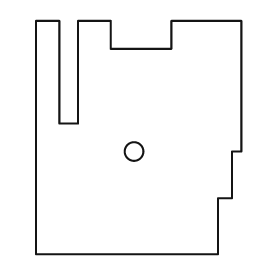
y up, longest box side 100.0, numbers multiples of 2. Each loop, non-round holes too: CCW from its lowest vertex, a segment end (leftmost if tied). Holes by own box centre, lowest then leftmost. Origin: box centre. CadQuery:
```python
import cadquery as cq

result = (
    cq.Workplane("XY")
    .moveTo(-44.0, -50.0)
    .lineTo(34.0, -50.0)
    .lineTo(34.0, -26.0)
    .lineTo(40.0, -26.0)
    .lineTo(40.0, -6.0)
    .lineTo(44.0, -6.0)
    .lineTo(44.0, 50.0)
    .lineTo(14.0, 50.0)
    .lineTo(14.0, 38.0)
    .lineTo(-12.0, 38.0)
    .lineTo(-12.0, 50.0)
    .lineTo(-26.0, 50.0)
    .lineTo(-26.0, 6.0)
    .lineTo(-34.0, 6.0)
    .lineTo(-34.0, 50.0)
    .lineTo(-44.0, 50.0)
    .close()
    .moveTo(-2.0, -6.0)
    .circle(4.0)
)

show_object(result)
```